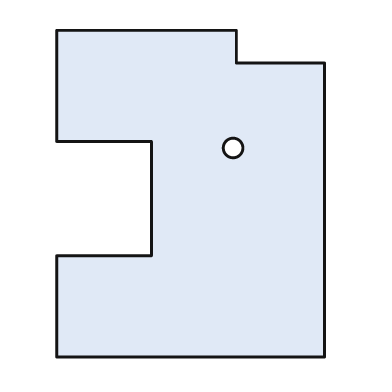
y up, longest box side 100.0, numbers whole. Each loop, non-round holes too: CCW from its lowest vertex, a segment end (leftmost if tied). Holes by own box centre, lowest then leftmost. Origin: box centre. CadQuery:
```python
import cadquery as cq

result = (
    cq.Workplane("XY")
    .moveTo(-41.0, -50.0)
    .lineTo(41.0, -50.0)
    .lineTo(41.0, 40.0)
    .lineTo(14.0, 40.0)
    .lineTo(14.0, 50.0)
    .lineTo(-41.0, 50.0)
    .lineTo(-41.0, 16.0)
    .lineTo(-12.0, 16.0)
    .lineTo(-12.0, -19.0)
    .lineTo(-41.0, -19.0)
    .close()
    .moveTo(13.0, 14.0)
    .circle(3.0)
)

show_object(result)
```